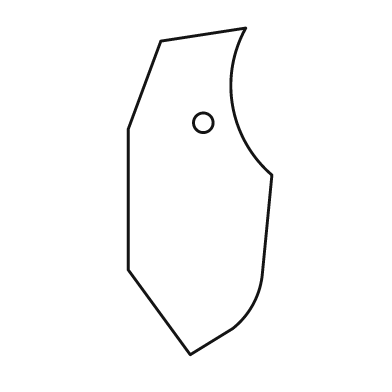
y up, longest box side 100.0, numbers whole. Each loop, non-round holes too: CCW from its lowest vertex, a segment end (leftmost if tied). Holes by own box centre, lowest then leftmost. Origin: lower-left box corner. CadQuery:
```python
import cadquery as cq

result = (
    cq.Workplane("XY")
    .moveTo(19.0, 0.0)
    .lineTo(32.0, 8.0)
    .threePointArc((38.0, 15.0), (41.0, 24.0))
    .lineTo(44.0, 55.0)
    .threePointArc((32.0, 76.0), (36.0, 100.0))
    .lineTo(10.0, 96.0)
    .lineTo(0.0, 69.0)
    .lineTo(0.0, 26.0)
    .close()
    .moveTo(23.0, 71.0)
    .circle(3.0)
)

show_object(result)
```